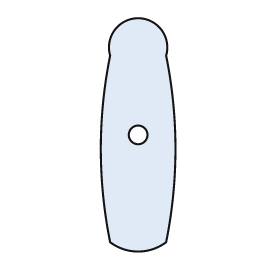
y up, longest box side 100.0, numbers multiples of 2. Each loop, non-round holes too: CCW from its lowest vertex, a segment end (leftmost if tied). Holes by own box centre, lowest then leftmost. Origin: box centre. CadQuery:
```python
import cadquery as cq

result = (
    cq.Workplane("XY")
    .moveTo(-12.0, -46.0)
    .threePointArc((0.0, -50.0), (12.0, -46.0))
    .threePointArc((16.0, -6.0), (12.0, 34.0))
    .threePointArc((0.0, 50.0), (-12.0, 34.0))
    .threePointArc((-16.0, -6.0), (-12.0, -46.0))
    .close()
    .moveTo(0.0, 0.0)
    .circle(4.0)
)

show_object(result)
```